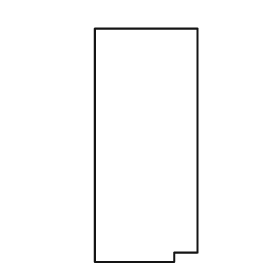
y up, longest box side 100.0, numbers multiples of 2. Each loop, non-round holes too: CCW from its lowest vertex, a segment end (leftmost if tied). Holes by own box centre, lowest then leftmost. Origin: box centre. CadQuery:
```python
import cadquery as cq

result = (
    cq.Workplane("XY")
    .moveTo(-22.0, -50.0)
    .lineTo(12.0, -50.0)
    .lineTo(12.0, -46.0)
    .lineTo(22.0, -46.0)
    .lineTo(22.0, 50.0)
    .lineTo(-22.0, 50.0)
    .close()
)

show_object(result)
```